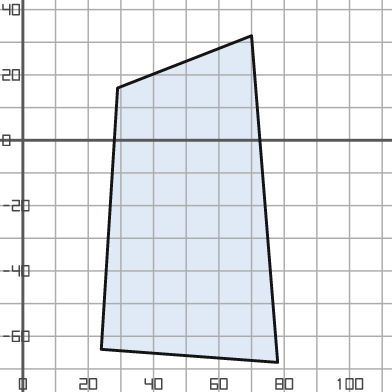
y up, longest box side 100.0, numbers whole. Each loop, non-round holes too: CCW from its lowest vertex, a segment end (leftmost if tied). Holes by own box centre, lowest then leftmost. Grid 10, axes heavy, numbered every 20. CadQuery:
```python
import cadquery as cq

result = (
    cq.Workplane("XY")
    .moveTo(78.0, -68.0)
    .lineTo(70.0, 32.0)
    .lineTo(29.0, 16.0)
    .lineTo(24.0, -64.0)
    .close()
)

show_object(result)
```